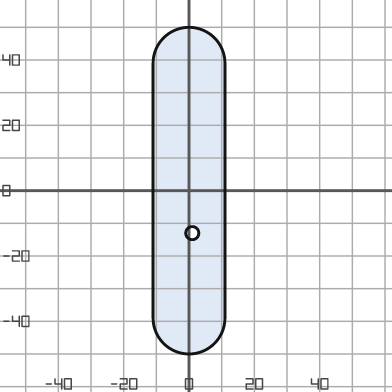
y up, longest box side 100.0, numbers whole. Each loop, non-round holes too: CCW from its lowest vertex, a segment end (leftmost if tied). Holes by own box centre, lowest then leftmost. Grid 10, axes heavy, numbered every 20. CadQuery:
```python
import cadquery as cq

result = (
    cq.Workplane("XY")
    .moveTo(-11.0, -39.0)
    .threePointArc((0.0, -50.0), (11.0, -39.0))
    .lineTo(11.0, 39.0)
    .threePointArc((0.0, 50.0), (-11.0, 39.0))
    .close()
    .moveTo(1.0, -13.0)
    .circle(2.0)
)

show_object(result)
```